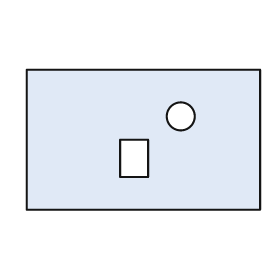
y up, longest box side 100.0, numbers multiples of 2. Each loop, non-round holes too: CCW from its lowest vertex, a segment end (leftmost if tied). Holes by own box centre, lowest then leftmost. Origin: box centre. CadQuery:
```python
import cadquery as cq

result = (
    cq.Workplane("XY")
    .moveTo(-50.0, -30.0)
    .lineTo(50.0, -30.0)
    .lineTo(50.0, 30.0)
    .lineTo(-50.0, 30.0)
    .close()
    .moveTo(-10.0, -16.0)
    .lineTo(2.0, -16.0)
    .lineTo(2.0, 0.0)
    .lineTo(-10.0, 0.0)
    .close()
    .moveTo(16.0, 10.0)
    .circle(6.0)
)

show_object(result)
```